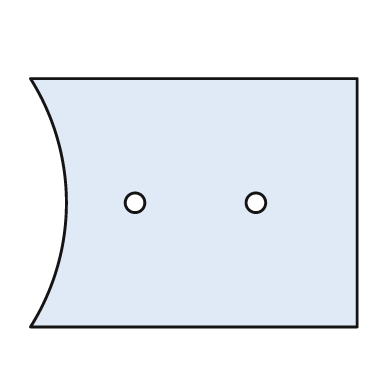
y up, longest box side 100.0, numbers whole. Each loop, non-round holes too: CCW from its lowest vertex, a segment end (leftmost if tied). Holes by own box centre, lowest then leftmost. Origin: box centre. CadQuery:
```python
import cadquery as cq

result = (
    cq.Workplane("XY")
    .moveTo(-50.0, -38.0)
    .lineTo(50.0, -38.0)
    .lineTo(50.0, 38.0)
    .lineTo(-50.0, 38.0)
    .threePointArc((-39.0, 0.0), (-50.0, -38.0))
    .close()
    .moveTo(-18.0, 0.0)
    .circle(3.0)
    .moveTo(19.0, 0.0)
    .circle(3.0)
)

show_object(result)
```